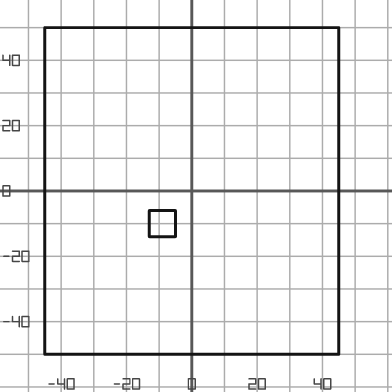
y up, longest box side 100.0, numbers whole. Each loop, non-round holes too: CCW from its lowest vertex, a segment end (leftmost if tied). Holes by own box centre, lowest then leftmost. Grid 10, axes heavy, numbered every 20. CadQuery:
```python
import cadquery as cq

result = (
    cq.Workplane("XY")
    .moveTo(-45.0, -50.0)
    .lineTo(45.0, -50.0)
    .lineTo(45.0, 50.0)
    .lineTo(-45.0, 50.0)
    .close()
    .moveTo(-13.0, -14.0)
    .lineTo(-5.0, -14.0)
    .lineTo(-5.0, -6.0)
    .lineTo(-13.0, -6.0)
    .close()
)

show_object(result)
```